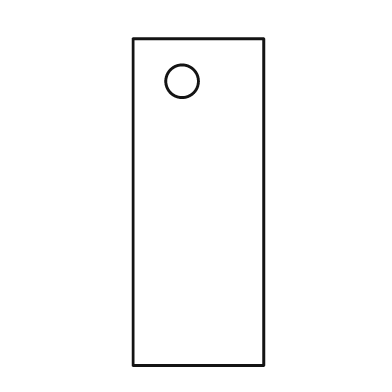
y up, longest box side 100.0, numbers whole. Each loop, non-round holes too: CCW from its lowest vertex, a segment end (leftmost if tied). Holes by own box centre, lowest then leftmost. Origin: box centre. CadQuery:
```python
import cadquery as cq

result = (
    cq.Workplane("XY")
    .moveTo(-20.0, -50.0)
    .lineTo(20.0, -50.0)
    .lineTo(20.0, 50.0)
    .lineTo(-20.0, 50.0)
    .close()
    .moveTo(-5.0, 37.0)
    .circle(5.0)
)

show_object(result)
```